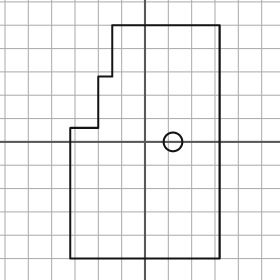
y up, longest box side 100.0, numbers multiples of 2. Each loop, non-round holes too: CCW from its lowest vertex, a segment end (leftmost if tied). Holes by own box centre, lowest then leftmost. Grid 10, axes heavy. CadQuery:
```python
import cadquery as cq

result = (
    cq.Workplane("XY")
    .moveTo(-32.0, -50.0)
    .lineTo(32.0, -50.0)
    .lineTo(32.0, 50.0)
    .lineTo(-14.0, 50.0)
    .lineTo(-14.0, 28.0)
    .lineTo(-20.0, 28.0)
    .lineTo(-20.0, 6.0)
    .lineTo(-32.0, 6.0)
    .close()
    .moveTo(12.0, 0.0)
    .circle(4.0)
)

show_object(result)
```